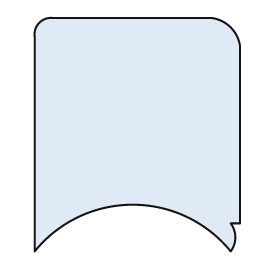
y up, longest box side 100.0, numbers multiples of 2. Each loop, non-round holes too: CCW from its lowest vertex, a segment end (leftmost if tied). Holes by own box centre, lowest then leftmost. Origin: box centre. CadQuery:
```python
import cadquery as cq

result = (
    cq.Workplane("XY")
    .moveTo(-44.0, -50.0)
    .threePointArc((-2.0, -30.0), (40.0, -50.0))
    .threePointArc((42.0, -44.0), (40.0, -38.0))
    .lineTo(44.0, -38.0)
    .lineTo(44.0, 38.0)
    .threePointArc((40.0, 46.0), (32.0, 50.0))
    .lineTo(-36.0, 50.0)
    .threePointArc((-42.0, 48.0), (-44.0, 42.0))
    .close()
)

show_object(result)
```